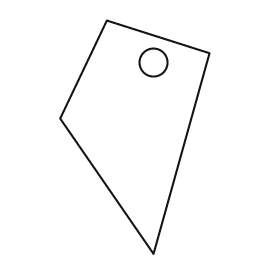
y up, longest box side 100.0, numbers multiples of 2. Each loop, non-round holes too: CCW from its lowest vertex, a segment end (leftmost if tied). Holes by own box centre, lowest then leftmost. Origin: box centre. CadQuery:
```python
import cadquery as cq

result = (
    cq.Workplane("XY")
    .moveTo(8.0, -50.0)
    .lineTo(32.0, 36.0)
    .lineTo(-12.0, 50.0)
    .lineTo(-32.0, 8.0)
    .close()
    .moveTo(8.0, 32.0)
    .circle(6.0)
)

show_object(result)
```